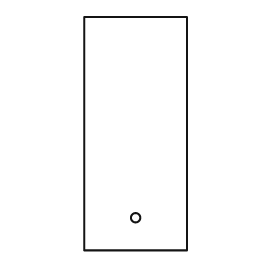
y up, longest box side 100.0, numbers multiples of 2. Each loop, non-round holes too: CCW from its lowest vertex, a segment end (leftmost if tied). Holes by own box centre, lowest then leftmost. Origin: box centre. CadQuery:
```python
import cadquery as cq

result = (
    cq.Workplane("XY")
    .moveTo(-22.0, -50.0)
    .lineTo(22.0, -50.0)
    .lineTo(22.0, 50.0)
    .lineTo(-22.0, 50.0)
    .close()
    .moveTo(0.0, -36.0)
    .circle(2.0)
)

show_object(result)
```